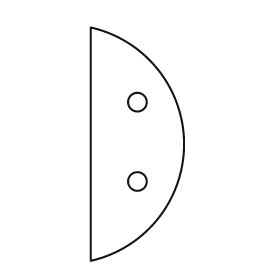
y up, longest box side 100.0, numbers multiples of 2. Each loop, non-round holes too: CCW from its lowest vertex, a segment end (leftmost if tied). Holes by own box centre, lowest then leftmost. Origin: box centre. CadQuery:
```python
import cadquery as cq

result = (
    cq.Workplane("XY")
    .moveTo(-20.0, -50.0)
    .threePointArc((20.0, 0.0), (-20.0, 50.0))
    .close()
    .moveTo(0.0, -16.0)
    .circle(4.0)
    .moveTo(0.0, 18.0)
    .circle(4.0)
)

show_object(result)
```